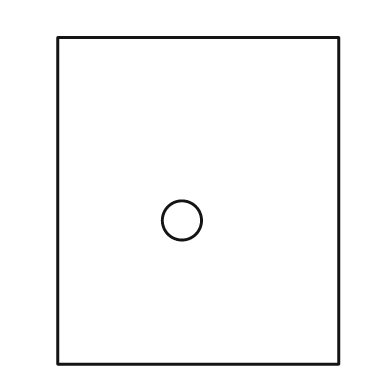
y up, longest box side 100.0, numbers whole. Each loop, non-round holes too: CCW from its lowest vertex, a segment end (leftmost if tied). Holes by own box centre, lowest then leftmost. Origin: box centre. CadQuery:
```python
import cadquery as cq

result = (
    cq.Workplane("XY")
    .moveTo(-43.0, -50.0)
    .lineTo(43.0, -50.0)
    .lineTo(43.0, 50.0)
    .lineTo(-43.0, 50.0)
    .close()
    .moveTo(-5.0, -6.0)
    .circle(6.0)
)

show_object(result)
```